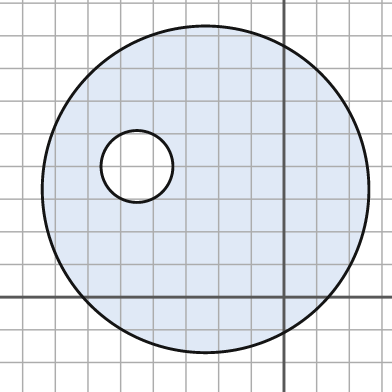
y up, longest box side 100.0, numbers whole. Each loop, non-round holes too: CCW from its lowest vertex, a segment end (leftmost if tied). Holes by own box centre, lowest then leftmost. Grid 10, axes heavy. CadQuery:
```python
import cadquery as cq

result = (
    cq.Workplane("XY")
    .moveTo(-24.0, 33.0)
    .circle(50.0)
    .moveTo(-45.0, 40.0)
    .circle(11.0)
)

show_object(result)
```